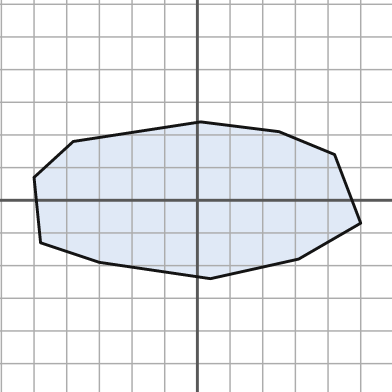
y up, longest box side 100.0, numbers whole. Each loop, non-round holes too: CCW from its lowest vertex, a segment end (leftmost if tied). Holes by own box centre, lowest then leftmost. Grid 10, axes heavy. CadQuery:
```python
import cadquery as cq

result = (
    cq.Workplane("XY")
    .moveTo(4.0, -24.0)
    .lineTo(31.0, -18.0)
    .lineTo(50.0, -7.0)
    .lineTo(42.0, 14.0)
    .lineTo(25.0, 21.0)
    .lineTo(1.0, 24.0)
    .lineTo(-38.0, 18.0)
    .lineTo(-50.0, 7.0)
    .lineTo(-48.0, -13.0)
    .lineTo(-30.0, -19.0)
    .close()
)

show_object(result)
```